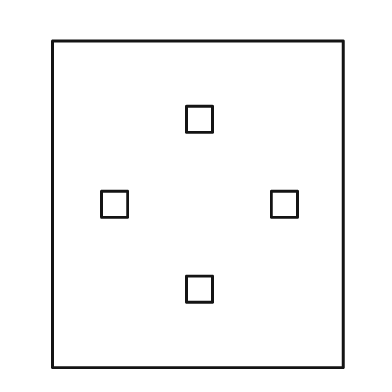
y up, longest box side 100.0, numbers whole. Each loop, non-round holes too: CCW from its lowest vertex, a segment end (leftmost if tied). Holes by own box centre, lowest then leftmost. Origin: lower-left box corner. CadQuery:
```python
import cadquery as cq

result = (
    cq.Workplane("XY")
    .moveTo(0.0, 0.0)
    .lineTo(89.0, 0.0)
    .lineTo(89.0, 100.0)
    .lineTo(0.0, 100.0)
    .close()
    .moveTo(41.0, 20.0)
    .lineTo(49.0, 20.0)
    .lineTo(49.0, 28.0)
    .lineTo(41.0, 28.0)
    .close()
    .moveTo(15.0, 46.0)
    .lineTo(23.0, 46.0)
    .lineTo(23.0, 54.0)
    .lineTo(15.0, 54.0)
    .close()
    .moveTo(67.0, 46.0)
    .lineTo(75.0, 46.0)
    .lineTo(75.0, 54.0)
    .lineTo(67.0, 54.0)
    .close()
    .moveTo(41.0, 72.0)
    .lineTo(49.0, 72.0)
    .lineTo(49.0, 80.0)
    .lineTo(41.0, 80.0)
    .close()
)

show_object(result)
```